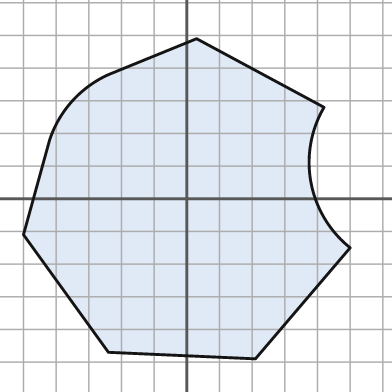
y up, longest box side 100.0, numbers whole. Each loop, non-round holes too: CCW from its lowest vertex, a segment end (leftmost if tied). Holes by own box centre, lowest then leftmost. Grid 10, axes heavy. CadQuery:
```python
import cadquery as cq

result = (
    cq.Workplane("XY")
    .moveTo(21.0, -49.0)
    .lineTo(50.0, -15.0)
    .threePointArc((38.0, 5.0), (42.0, 28.0))
    .lineTo(3.0, 49.0)
    .lineTo(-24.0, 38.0)
    .threePointArc((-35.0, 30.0), (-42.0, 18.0))
    .lineTo(-50.0, -11.0)
    .lineTo(-24.0, -47.0)
    .close()
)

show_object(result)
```